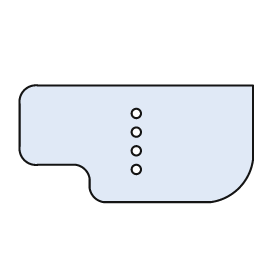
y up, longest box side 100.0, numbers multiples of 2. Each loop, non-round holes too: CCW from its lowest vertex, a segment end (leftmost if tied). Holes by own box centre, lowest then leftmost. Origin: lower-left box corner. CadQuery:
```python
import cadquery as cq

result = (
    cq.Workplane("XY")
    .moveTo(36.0, 0.0)
    .lineTo(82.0, 0.0)
    .threePointArc((94.0, 6.0), (100.0, 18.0))
    .lineTo(100.0, 50.0)
    .lineTo(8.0, 50.0)
    .threePointArc((2.0, 48.0), (0.0, 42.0))
    .lineTo(0.0, 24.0)
    .threePointArc((2.0, 18.0), (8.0, 16.0))
    .lineTo(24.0, 16.0)
    .threePointArc((28.0, 14.0), (30.0, 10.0))
    .lineTo(30.0, 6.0)
    .threePointArc((32.0, 2.0), (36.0, 0.0))
    .close()
    .moveTo(50.0, 14.0)
    .circle(2.0)
    .moveTo(50.0, 22.0)
    .circle(2.0)
    .moveTo(50.0, 30.0)
    .circle(2.0)
    .moveTo(50.0, 38.0)
    .circle(2.0)
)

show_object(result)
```